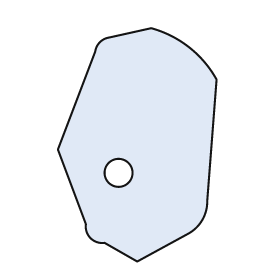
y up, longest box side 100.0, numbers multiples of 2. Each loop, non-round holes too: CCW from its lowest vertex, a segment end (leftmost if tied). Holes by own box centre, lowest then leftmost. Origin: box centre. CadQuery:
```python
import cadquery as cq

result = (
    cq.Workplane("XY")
    .moveTo(0.0, -50.0)
    .lineTo(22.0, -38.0)
    .threePointArc((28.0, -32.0), (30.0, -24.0))
    .lineTo(34.0, 28.0)
    .threePointArc((22.0, 42.0), (6.0, 50.0))
    .lineTo(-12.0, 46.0)
    .threePointArc((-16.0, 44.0), (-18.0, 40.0))
    .lineTo(-34.0, -2.0)
    .lineTo(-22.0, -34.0)
    .threePointArc((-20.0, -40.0), (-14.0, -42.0))
    .close()
    .moveTo(-8.0, -12.0)
    .circle(6.0)
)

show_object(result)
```